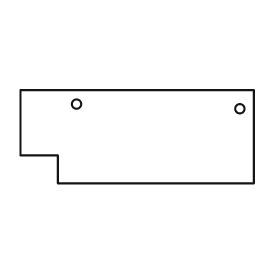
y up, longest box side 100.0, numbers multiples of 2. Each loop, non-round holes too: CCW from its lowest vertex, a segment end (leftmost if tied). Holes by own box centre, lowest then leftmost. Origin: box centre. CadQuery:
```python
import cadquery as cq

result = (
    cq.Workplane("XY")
    .moveTo(-34.0, -20.0)
    .lineTo(50.0, -20.0)
    .lineTo(50.0, 20.0)
    .lineTo(-50.0, 20.0)
    .lineTo(-50.0, -8.0)
    .lineTo(-34.0, -8.0)
    .close()
    .moveTo(44.0, 12.0)
    .circle(2.0)
    .moveTo(-26.0, 14.0)
    .circle(2.0)
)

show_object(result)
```